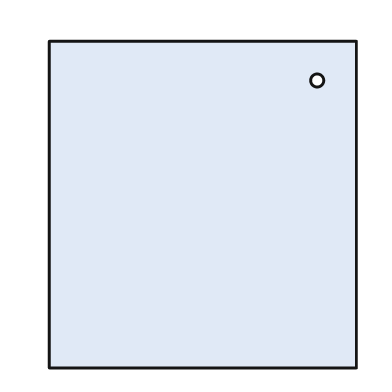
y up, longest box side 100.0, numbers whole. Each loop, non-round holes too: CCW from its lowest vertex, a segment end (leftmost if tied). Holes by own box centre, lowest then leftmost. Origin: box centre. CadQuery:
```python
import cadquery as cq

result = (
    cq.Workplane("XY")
    .moveTo(-47.0, -50.0)
    .lineTo(47.0, -50.0)
    .lineTo(47.0, 50.0)
    .lineTo(-47.0, 50.0)
    .close()
    .moveTo(35.0, 38.0)
    .circle(2.0)
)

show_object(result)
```